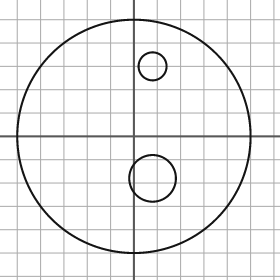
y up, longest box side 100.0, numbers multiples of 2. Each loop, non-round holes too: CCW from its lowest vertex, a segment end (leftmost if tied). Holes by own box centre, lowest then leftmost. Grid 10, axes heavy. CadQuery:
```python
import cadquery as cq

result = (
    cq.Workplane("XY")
    .moveTo(0.0, 0.0)
    .circle(50.0)
    .moveTo(8.0, -18.0)
    .circle(10.0)
    .moveTo(8.0, 30.0)
    .circle(6.0)
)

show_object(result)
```